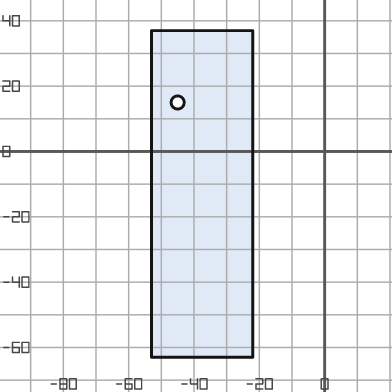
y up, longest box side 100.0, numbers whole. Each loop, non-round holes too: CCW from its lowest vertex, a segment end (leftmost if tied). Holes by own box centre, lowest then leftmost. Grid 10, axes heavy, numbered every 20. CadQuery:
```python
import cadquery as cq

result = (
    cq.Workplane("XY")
    .moveTo(-53.0, -63.0)
    .lineTo(-22.0, -63.0)
    .lineTo(-22.0, 37.0)
    .lineTo(-53.0, 37.0)
    .close()
    .moveTo(-45.0, 15.0)
    .circle(2.0)
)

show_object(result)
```